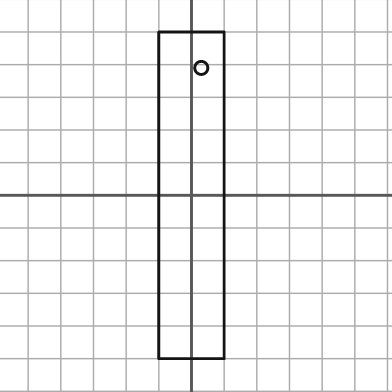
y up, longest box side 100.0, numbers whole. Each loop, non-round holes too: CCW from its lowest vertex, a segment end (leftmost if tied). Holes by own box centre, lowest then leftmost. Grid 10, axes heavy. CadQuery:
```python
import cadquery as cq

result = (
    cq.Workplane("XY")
    .moveTo(-10.0, -50.0)
    .lineTo(10.0, -50.0)
    .lineTo(10.0, 50.0)
    .lineTo(-10.0, 50.0)
    .close()
    .moveTo(3.0, 39.0)
    .circle(2.0)
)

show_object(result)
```